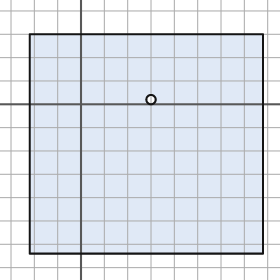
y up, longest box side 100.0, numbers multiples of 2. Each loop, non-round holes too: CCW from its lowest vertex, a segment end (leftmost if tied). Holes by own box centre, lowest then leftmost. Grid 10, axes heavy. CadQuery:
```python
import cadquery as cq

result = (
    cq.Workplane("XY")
    .moveTo(-22.0, -64.0)
    .lineTo(78.0, -64.0)
    .lineTo(78.0, 30.0)
    .lineTo(-22.0, 30.0)
    .close()
    .moveTo(30.0, 2.0)
    .circle(2.0)
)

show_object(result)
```